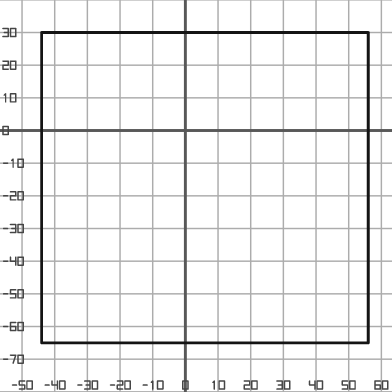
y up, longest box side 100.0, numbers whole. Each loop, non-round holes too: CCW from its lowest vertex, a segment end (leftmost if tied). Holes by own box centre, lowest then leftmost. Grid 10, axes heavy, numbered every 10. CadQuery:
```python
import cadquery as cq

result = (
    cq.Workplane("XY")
    .moveTo(-44.0, -65.0)
    .lineTo(56.0, -65.0)
    .lineTo(56.0, 30.0)
    .lineTo(-44.0, 30.0)
    .close()
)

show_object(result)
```